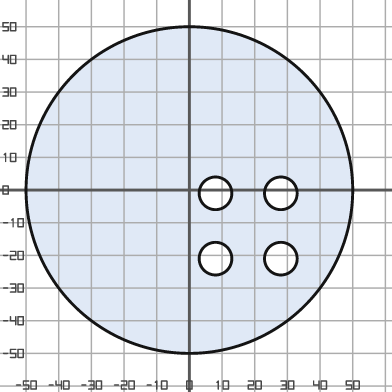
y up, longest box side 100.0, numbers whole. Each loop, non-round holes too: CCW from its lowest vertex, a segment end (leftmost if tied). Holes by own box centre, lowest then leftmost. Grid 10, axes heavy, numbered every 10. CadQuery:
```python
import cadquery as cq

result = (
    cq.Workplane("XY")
    .moveTo(0.0, 0.0)
    .circle(50.0)
    .moveTo(8.0, -21.0)
    .circle(5.0)
    .moveTo(28.0, -21.0)
    .circle(5.0)
    .moveTo(8.0, -1.0)
    .circle(5.0)
    .moveTo(28.0, -1.0)
    .circle(5.0)
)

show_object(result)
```